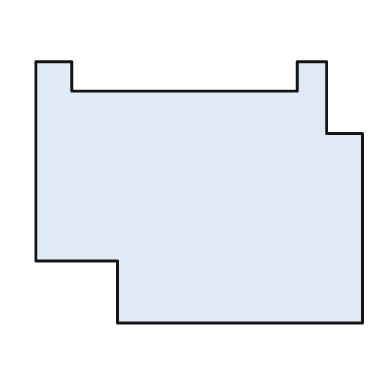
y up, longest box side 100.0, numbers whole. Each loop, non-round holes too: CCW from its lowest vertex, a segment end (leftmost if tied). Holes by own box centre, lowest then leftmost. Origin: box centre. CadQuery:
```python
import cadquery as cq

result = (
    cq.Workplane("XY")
    .moveTo(-25.0, -40.0)
    .lineTo(50.0, -40.0)
    .lineTo(50.0, 18.0)
    .lineTo(39.0, 18.0)
    .lineTo(39.0, 40.0)
    .lineTo(30.0, 40.0)
    .lineTo(30.0, 31.0)
    .lineTo(-39.0, 31.0)
    .lineTo(-39.0, 40.0)
    .lineTo(-50.0, 40.0)
    .lineTo(-50.0, -21.0)
    .lineTo(-25.0, -21.0)
    .close()
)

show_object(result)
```